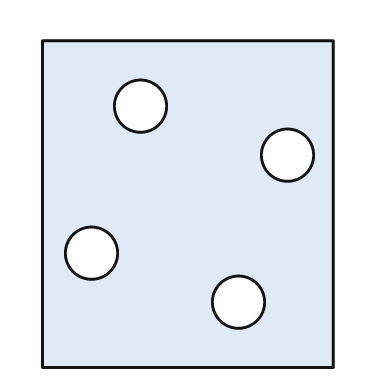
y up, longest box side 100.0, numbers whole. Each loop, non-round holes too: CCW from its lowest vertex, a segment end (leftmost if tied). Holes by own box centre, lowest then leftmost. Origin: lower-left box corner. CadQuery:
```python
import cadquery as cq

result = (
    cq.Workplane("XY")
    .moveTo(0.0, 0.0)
    .lineTo(89.0, 0.0)
    .lineTo(89.0, 100.0)
    .lineTo(0.0, 100.0)
    .close()
    .moveTo(60.0, 20.0)
    .circle(8.0)
    .moveTo(15.0, 35.0)
    .circle(8.0)
    .moveTo(75.0, 65.0)
    .circle(8.0)
    .moveTo(30.0, 80.0)
    .circle(8.0)
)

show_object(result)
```